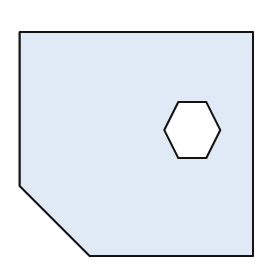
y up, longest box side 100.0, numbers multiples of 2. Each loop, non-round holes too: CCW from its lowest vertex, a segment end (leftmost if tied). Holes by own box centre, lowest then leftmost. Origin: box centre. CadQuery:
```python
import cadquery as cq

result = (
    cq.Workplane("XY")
    .moveTo(-20.0, -48.0)
    .lineTo(50.0, -48.0)
    .lineTo(50.0, 48.0)
    .lineTo(-50.0, 48.0)
    .lineTo(-50.0, -18.0)
    .close()
    .moveTo(18.0, -6.0)
    .lineTo(30.0, -6.0)
    .lineTo(36.0, 6.0)
    .lineTo(30.0, 18.0)
    .lineTo(18.0, 18.0)
    .lineTo(12.0, 6.0)
    .close()
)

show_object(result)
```